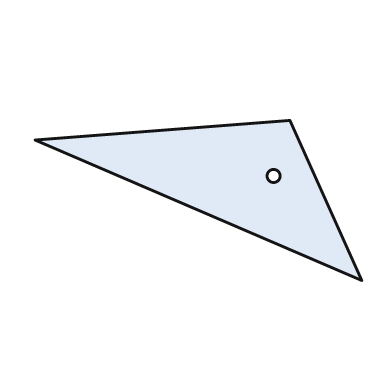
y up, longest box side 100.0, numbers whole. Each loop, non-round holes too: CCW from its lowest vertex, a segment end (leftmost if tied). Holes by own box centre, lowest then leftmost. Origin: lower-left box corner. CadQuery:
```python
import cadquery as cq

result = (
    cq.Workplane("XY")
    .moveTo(100.0, 0.0)
    .lineTo(78.0, 49.0)
    .lineTo(0.0, 43.0)
    .close()
    .moveTo(73.0, 32.0)
    .circle(2.0)
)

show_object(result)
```